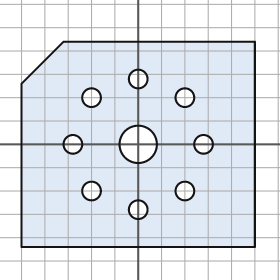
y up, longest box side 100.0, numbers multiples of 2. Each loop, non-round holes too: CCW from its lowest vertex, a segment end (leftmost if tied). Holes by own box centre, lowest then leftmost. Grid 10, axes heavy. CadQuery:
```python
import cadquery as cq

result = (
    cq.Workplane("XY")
    .moveTo(-50.0, -44.0)
    .lineTo(50.0, -44.0)
    .lineTo(50.0, 44.0)
    .lineTo(-32.0, 44.0)
    .lineTo(-50.0, 26.0)
    .close()
    .moveTo(0.0, -28.0)
    .circle(4.0)
    .moveTo(-20.0, -20.0)
    .circle(4.0)
    .moveTo(20.0, -20.0)
    .circle(4.0)
    .moveTo(-28.0, 0.0)
    .circle(4.0)
    .moveTo(0.0, 0.0)
    .circle(8.0)
    .moveTo(28.0, 0.0)
    .circle(4.0)
    .moveTo(-20.0, 20.0)
    .circle(4.0)
    .moveTo(20.0, 20.0)
    .circle(4.0)
    .moveTo(0.0, 28.0)
    .circle(4.0)
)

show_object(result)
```